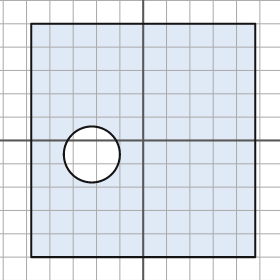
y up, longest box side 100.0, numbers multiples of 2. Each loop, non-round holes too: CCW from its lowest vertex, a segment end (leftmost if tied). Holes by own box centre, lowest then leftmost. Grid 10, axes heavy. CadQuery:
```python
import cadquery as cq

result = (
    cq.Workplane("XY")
    .moveTo(-48.0, -50.0)
    .lineTo(48.0, -50.0)
    .lineTo(48.0, 50.0)
    .lineTo(-48.0, 50.0)
    .close()
    .moveTo(-22.0, -6.0)
    .circle(12.0)
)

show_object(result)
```